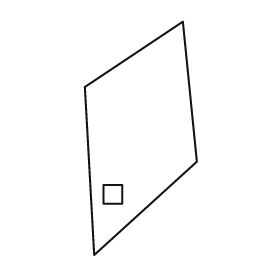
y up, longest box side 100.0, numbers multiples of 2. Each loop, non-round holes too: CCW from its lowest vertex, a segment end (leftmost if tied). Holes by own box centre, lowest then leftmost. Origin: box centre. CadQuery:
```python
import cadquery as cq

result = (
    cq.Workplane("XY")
    .moveTo(-20.0, -50.0)
    .lineTo(24.0, -10.0)
    .lineTo(18.0, 50.0)
    .lineTo(-24.0, 22.0)
    .close()
    .moveTo(-16.0, -28.0)
    .lineTo(-8.0, -28.0)
    .lineTo(-8.0, -20.0)
    .lineTo(-16.0, -20.0)
    .close()
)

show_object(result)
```